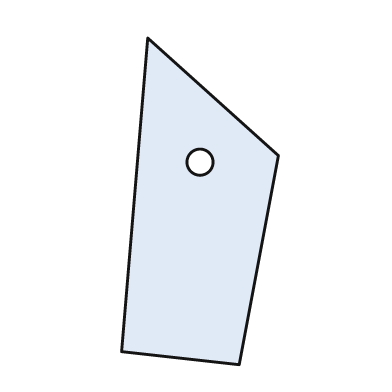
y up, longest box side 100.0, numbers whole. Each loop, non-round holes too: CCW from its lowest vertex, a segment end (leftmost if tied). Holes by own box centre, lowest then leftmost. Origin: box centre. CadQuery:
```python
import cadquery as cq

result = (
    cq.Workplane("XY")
    .moveTo(12.0, -50.0)
    .lineTo(24.0, 14.0)
    .lineTo(-16.0, 50.0)
    .lineTo(-24.0, -46.0)
    .close()
    .moveTo(0.0, 12.0)
    .circle(4.0)
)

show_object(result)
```